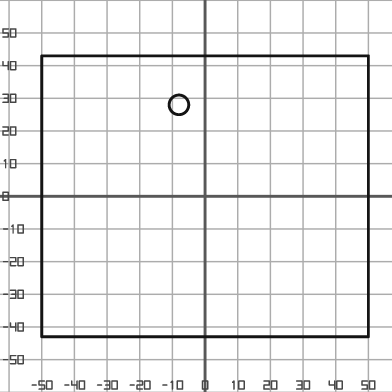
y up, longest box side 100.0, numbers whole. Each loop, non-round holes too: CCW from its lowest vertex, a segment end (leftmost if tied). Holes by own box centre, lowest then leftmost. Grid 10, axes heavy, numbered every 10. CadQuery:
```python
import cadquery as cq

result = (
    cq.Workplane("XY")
    .moveTo(-50.0, -43.0)
    .lineTo(50.0, -43.0)
    .lineTo(50.0, 43.0)
    .lineTo(-50.0, 43.0)
    .close()
    .moveTo(-8.0, 28.0)
    .circle(3.0)
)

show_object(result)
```